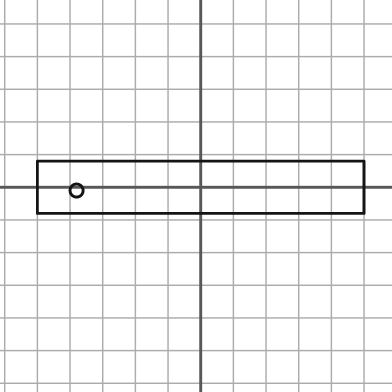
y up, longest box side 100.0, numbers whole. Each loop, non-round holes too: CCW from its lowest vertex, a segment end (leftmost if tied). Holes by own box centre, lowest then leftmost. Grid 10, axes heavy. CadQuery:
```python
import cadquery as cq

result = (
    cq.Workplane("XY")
    .moveTo(-50.0, -8.0)
    .lineTo(50.0, -8.0)
    .lineTo(50.0, 8.0)
    .lineTo(-50.0, 8.0)
    .close()
    .moveTo(-38.0, -1.0)
    .circle(2.0)
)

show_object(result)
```